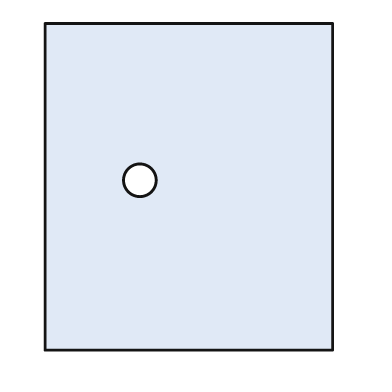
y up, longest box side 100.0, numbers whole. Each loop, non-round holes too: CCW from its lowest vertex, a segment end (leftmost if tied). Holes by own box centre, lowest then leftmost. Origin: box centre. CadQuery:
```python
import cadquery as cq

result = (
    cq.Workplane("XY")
    .moveTo(-44.0, -50.0)
    .lineTo(44.0, -50.0)
    .lineTo(44.0, 50.0)
    .lineTo(-44.0, 50.0)
    .close()
    .moveTo(-15.0, 2.0)
    .circle(5.0)
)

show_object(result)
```